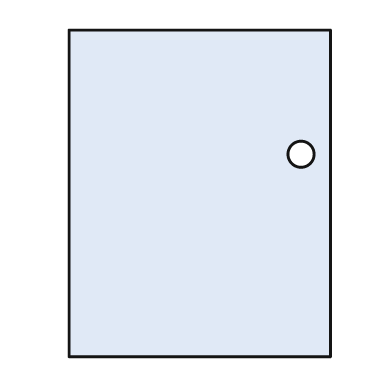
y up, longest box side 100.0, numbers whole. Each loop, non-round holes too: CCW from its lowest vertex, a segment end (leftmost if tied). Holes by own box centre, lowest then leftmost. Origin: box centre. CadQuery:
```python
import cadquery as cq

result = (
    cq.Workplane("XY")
    .moveTo(-40.0, -50.0)
    .lineTo(40.0, -50.0)
    .lineTo(40.0, 50.0)
    .lineTo(-40.0, 50.0)
    .close()
    .moveTo(31.0, 12.0)
    .circle(4.0)
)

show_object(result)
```